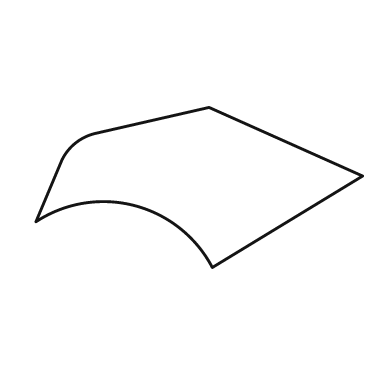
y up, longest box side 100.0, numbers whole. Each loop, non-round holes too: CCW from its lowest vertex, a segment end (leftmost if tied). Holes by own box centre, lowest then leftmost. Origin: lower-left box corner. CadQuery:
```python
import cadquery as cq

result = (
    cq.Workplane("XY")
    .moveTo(54.0, 0.0)
    .lineTo(100.0, 28.0)
    .lineTo(53.0, 49.0)
    .lineTo(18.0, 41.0)
    .threePointArc((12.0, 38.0), (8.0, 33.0))
    .lineTo(0.0, 14.0)
    .threePointArc((30.0, 19.0), (54.0, 0.0))
    .close()
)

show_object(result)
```